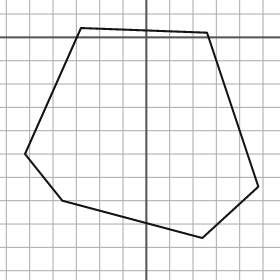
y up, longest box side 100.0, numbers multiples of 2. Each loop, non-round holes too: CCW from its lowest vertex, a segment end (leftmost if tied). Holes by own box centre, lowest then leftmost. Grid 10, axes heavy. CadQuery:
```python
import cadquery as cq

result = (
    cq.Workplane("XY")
    .moveTo(24.0, -86.0)
    .lineTo(48.0, -64.0)
    .lineTo(26.0, 2.0)
    .lineTo(-28.0, 4.0)
    .lineTo(-52.0, -50.0)
    .lineTo(-36.0, -70.0)
    .close()
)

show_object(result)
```